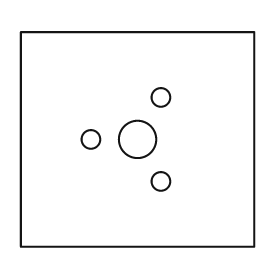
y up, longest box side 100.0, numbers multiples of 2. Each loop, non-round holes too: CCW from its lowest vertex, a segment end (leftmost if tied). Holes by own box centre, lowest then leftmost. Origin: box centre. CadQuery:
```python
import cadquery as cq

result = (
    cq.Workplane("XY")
    .moveTo(-50.0, -46.0)
    .lineTo(50.0, -46.0)
    .lineTo(50.0, 46.0)
    .lineTo(-50.0, 46.0)
    .close()
    .moveTo(10.0, -18.0)
    .circle(4.0)
    .moveTo(-20.0, 0.0)
    .circle(4.0)
    .moveTo(0.0, 0.0)
    .circle(8.0)
    .moveTo(10.0, 18.0)
    .circle(4.0)
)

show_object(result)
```